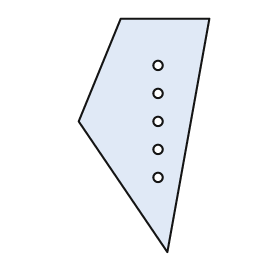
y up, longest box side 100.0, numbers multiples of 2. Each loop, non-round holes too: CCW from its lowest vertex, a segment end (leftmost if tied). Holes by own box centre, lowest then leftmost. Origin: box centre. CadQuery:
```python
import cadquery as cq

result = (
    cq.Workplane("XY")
    .moveTo(10.0, -50.0)
    .lineTo(28.0, 50.0)
    .lineTo(-10.0, 50.0)
    .lineTo(-28.0, 6.0)
    .close()
    .moveTo(6.0, -18.0)
    .circle(2.0)
    .moveTo(6.0, -6.0)
    .circle(2.0)
    .moveTo(6.0, 6.0)
    .circle(2.0)
    .moveTo(6.0, 18.0)
    .circle(2.0)
    .moveTo(6.0, 30.0)
    .circle(2.0)
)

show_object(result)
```